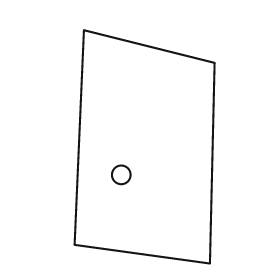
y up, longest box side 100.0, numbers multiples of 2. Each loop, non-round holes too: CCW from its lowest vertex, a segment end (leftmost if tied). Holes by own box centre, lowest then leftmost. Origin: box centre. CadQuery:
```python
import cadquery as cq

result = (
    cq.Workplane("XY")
    .moveTo(28.0, -50.0)
    .lineTo(30.0, 36.0)
    .lineTo(-26.0, 50.0)
    .lineTo(-30.0, -42.0)
    .close()
    .moveTo(-10.0, -12.0)
    .circle(4.0)
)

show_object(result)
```